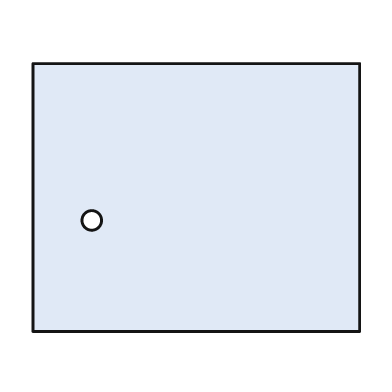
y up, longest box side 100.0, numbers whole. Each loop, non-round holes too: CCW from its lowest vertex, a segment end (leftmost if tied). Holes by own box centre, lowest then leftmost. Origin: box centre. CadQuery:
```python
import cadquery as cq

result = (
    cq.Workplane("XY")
    .moveTo(-50.0, -41.0)
    .lineTo(50.0, -41.0)
    .lineTo(50.0, 41.0)
    .lineTo(-50.0, 41.0)
    .close()
    .moveTo(-32.0, -7.0)
    .circle(3.0)
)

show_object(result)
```